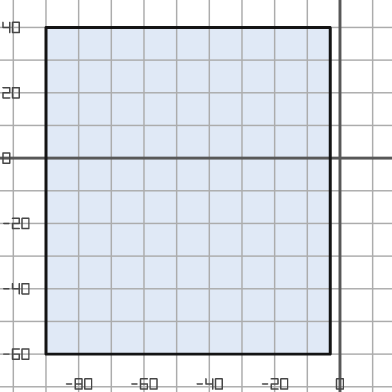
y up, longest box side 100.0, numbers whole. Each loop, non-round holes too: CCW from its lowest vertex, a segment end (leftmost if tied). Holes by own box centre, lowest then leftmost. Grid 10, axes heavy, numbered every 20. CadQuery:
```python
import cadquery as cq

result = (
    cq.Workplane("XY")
    .moveTo(-90.0, -60.0)
    .lineTo(-3.0, -60.0)
    .lineTo(-3.0, 40.0)
    .lineTo(-90.0, 40.0)
    .close()
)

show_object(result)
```